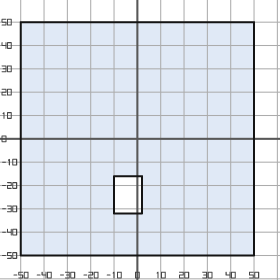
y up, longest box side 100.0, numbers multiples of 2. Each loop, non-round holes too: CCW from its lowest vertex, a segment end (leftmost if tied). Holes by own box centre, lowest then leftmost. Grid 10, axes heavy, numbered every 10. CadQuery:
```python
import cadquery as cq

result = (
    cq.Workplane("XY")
    .moveTo(-50.0, -50.0)
    .lineTo(50.0, -50.0)
    .lineTo(50.0, 50.0)
    .lineTo(-50.0, 50.0)
    .close()
    .moveTo(-10.0, -32.0)
    .lineTo(2.0, -32.0)
    .lineTo(2.0, -16.0)
    .lineTo(-10.0, -16.0)
    .close()
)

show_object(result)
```